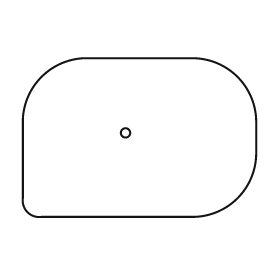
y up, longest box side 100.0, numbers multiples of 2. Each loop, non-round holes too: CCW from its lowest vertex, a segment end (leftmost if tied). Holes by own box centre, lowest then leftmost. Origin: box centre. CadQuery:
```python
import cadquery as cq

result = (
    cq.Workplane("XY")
    .moveTo(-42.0, -34.0)
    .lineTo(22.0, -34.0)
    .threePointArc((42.0, -26.0), (50.0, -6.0))
    .lineTo(50.0, 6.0)
    .threePointArc((42.0, 26.0), (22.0, 34.0))
    .lineTo(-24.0, 34.0)
    .threePointArc((-42.0, 26.0), (-50.0, 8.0))
    .lineTo(-50.0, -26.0)
    .threePointArc((-48.0, -32.0), (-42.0, -34.0))
    .close()
    .moveTo(-6.0, 2.0)
    .circle(2.0)
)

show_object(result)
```